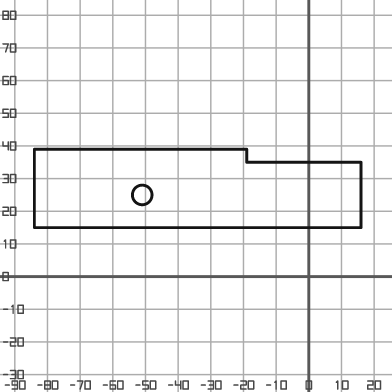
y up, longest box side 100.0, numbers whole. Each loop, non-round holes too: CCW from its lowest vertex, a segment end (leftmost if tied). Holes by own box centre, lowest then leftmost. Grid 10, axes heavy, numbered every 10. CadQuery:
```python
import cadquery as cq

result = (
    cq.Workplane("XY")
    .moveTo(-84.0, 15.0)
    .lineTo(16.0, 15.0)
    .lineTo(16.0, 35.0)
    .lineTo(-19.0, 35.0)
    .lineTo(-19.0, 39.0)
    .lineTo(-84.0, 39.0)
    .close()
    .moveTo(-51.0, 25.0)
    .circle(3.0)
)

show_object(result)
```